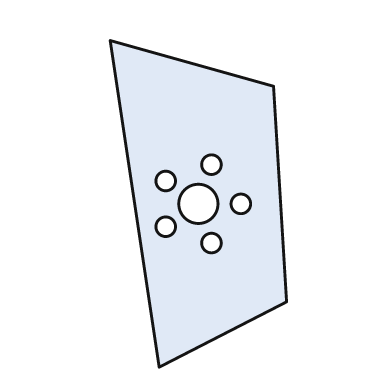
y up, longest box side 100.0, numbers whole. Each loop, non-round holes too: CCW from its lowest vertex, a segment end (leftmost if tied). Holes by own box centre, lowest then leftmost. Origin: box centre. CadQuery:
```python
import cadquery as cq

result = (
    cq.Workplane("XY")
    .moveTo(-12.0, -50.0)
    .lineTo(27.0, -30.0)
    .lineTo(23.0, 36.0)
    .lineTo(-27.0, 50.0)
    .close()
    .moveTo(4.0, -12.0)
    .circle(3.0)
    .moveTo(-10.0, -7.0)
    .circle(3.0)
    .moveTo(0.0, 0.0)
    .circle(6.0)
    .moveTo(13.0, 0.0)
    .circle(3.0)
    .moveTo(-10.0, 7.0)
    .circle(3.0)
    .moveTo(4.0, 12.0)
    .circle(3.0)
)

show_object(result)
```